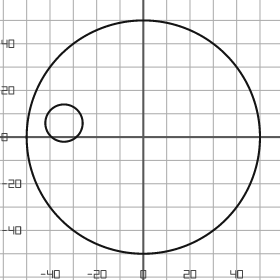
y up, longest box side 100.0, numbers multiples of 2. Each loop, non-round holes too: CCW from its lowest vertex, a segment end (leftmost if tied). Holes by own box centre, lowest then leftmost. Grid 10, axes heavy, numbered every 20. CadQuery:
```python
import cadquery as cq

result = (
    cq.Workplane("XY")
    .moveTo(0.0, 0.0)
    .circle(50.0)
    .moveTo(-34.0, 6.0)
    .circle(8.0)
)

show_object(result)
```